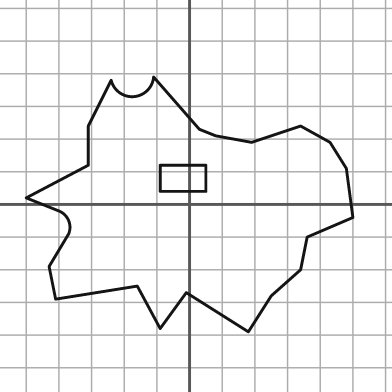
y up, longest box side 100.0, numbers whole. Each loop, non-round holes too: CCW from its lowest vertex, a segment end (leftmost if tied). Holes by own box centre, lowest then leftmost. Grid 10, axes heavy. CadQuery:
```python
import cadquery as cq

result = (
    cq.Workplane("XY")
    .moveTo(18.0, -39.0)
    .lineTo(25.0, -28.0)
    .lineTo(34.0, -20.0)
    .lineTo(36.0, -10.0)
    .lineTo(50.0, -4.0)
    .lineTo(48.0, 11.0)
    .lineTo(43.0, 19.0)
    .lineTo(34.0, 24.0)
    .lineTo(19.0, 19.0)
    .lineTo(8.0, 21.0)
    .lineTo(3.0, 23.0)
    .lineTo(-11.0, 39.0)
    .threePointArc((-17.0, 33.0), (-24.0, 38.0))
    .lineTo(-31.0, 24.0)
    .lineTo(-31.0, 12.0)
    .lineTo(-50.0, 2.0)
    .lineTo(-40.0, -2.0)
    .threePointArc((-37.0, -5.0), (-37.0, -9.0))
    .lineTo(-43.0, -19.0)
    .lineTo(-41.0, -29.0)
    .lineTo(-16.0, -25.0)
    .lineTo(-9.0, -38.0)
    .lineTo(-1.0, -27.0)
    .close()
    .moveTo(-9.0, 4.0)
    .lineTo(5.0, 4.0)
    .lineTo(5.0, 12.0)
    .lineTo(-9.0, 12.0)
    .close()
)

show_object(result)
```